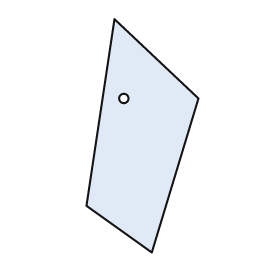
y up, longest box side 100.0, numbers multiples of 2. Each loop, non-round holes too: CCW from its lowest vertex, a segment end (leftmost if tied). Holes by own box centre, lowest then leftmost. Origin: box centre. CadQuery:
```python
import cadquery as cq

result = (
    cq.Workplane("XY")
    .moveTo(4.0, -50.0)
    .lineTo(24.0, 16.0)
    .lineTo(-12.0, 50.0)
    .lineTo(-24.0, -30.0)
    .close()
    .moveTo(-8.0, 16.0)
    .circle(2.0)
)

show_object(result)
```